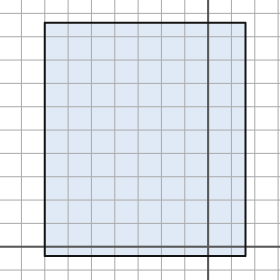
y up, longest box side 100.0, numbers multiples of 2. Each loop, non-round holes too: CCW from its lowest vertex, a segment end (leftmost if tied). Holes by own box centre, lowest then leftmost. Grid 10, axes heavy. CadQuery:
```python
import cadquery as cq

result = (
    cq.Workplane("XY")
    .moveTo(-70.0, -4.0)
    .lineTo(16.0, -4.0)
    .lineTo(16.0, 96.0)
    .lineTo(-70.0, 96.0)
    .close()
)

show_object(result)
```